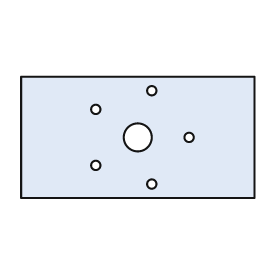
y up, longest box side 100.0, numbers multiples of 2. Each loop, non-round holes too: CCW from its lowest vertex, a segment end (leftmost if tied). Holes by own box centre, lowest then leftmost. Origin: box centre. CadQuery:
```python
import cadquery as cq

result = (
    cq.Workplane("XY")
    .moveTo(-50.0, -26.0)
    .lineTo(50.0, -26.0)
    .lineTo(50.0, 26.0)
    .lineTo(-50.0, 26.0)
    .close()
    .moveTo(6.0, -20.0)
    .circle(2.0)
    .moveTo(-18.0, -12.0)
    .circle(2.0)
    .moveTo(0.0, 0.0)
    .circle(6.0)
    .moveTo(22.0, 0.0)
    .circle(2.0)
    .moveTo(-18.0, 12.0)
    .circle(2.0)
    .moveTo(6.0, 20.0)
    .circle(2.0)
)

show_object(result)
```